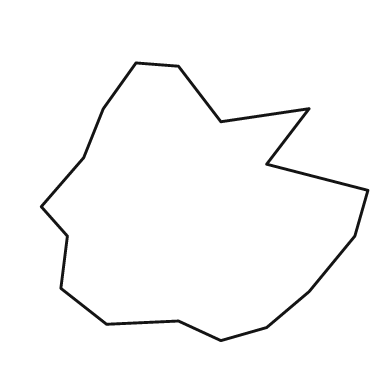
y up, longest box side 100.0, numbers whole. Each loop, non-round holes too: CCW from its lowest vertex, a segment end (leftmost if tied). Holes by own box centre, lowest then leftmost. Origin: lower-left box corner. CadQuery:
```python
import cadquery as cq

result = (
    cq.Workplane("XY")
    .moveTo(55.0, 0.0)
    .lineTo(69.0, 4.0)
    .lineTo(82.0, 15.0)
    .lineTo(96.0, 32.0)
    .lineTo(100.0, 46.0)
    .lineTo(69.0, 54.0)
    .lineTo(82.0, 71.0)
    .lineTo(55.0, 67.0)
    .lineTo(42.0, 84.0)
    .lineTo(29.0, 85.0)
    .lineTo(19.0, 71.0)
    .lineTo(13.0, 56.0)
    .lineTo(0.0, 41.0)
    .lineTo(8.0, 32.0)
    .lineTo(6.0, 16.0)
    .lineTo(20.0, 5.0)
    .lineTo(42.0, 6.0)
    .close()
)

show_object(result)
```